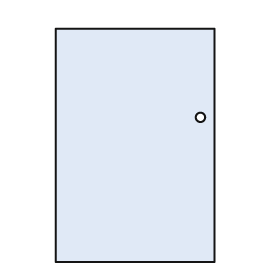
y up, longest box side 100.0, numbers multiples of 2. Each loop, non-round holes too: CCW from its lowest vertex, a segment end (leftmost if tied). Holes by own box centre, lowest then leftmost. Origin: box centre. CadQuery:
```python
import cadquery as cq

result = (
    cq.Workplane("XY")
    .moveTo(-34.0, -50.0)
    .lineTo(34.0, -50.0)
    .lineTo(34.0, 50.0)
    .lineTo(-34.0, 50.0)
    .close()
    .moveTo(28.0, 12.0)
    .circle(2.0)
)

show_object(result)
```